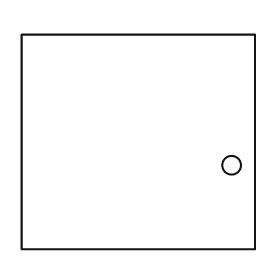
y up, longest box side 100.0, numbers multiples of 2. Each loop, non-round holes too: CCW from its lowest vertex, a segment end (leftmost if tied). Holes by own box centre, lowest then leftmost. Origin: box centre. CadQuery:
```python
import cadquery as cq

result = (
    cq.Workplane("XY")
    .moveTo(-50.0, -46.0)
    .lineTo(50.0, -46.0)
    .lineTo(50.0, 46.0)
    .lineTo(-50.0, 46.0)
    .close()
    .moveTo(40.0, -10.0)
    .circle(4.0)
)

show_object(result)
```